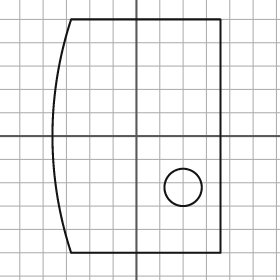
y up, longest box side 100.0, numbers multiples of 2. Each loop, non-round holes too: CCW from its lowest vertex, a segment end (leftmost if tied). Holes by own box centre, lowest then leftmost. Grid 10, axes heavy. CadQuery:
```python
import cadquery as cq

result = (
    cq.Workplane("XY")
    .moveTo(-28.0, -50.0)
    .lineTo(36.0, -50.0)
    .lineTo(36.0, 50.0)
    .lineTo(-28.0, 50.0)
    .threePointArc((-36.0, 0.0), (-28.0, -50.0))
    .close()
    .moveTo(20.0, -22.0)
    .circle(8.0)
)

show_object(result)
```